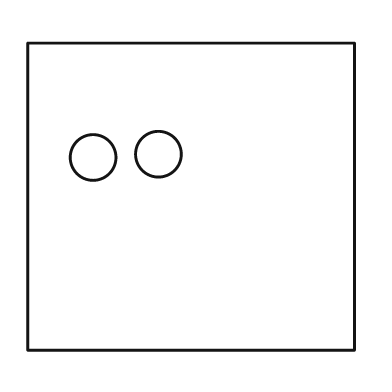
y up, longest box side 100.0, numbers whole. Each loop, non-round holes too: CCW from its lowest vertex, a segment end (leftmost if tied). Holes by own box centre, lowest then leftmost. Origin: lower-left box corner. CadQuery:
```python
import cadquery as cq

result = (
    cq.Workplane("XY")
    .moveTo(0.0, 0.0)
    .lineTo(100.0, 0.0)
    .lineTo(100.0, 94.0)
    .lineTo(0.0, 94.0)
    .close()
    .moveTo(20.0, 59.0)
    .circle(7.0)
    .moveTo(40.0, 60.0)
    .circle(7.0)
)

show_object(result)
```